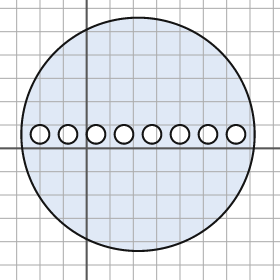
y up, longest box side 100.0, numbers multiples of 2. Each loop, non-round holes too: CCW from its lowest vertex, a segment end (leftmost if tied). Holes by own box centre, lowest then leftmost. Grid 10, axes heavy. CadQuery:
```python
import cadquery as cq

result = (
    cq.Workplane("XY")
    .moveTo(22.0, 6.0)
    .circle(50.0)
    .moveTo(-20.0, 6.0)
    .circle(4.0)
    .moveTo(-8.0, 6.0)
    .circle(4.0)
    .moveTo(4.0, 6.0)
    .circle(4.0)
    .moveTo(16.0, 6.0)
    .circle(4.0)
    .moveTo(28.0, 6.0)
    .circle(4.0)
    .moveTo(40.0, 6.0)
    .circle(4.0)
    .moveTo(52.0, 6.0)
    .circle(4.0)
    .moveTo(64.0, 6.0)
    .circle(4.0)
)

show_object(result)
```